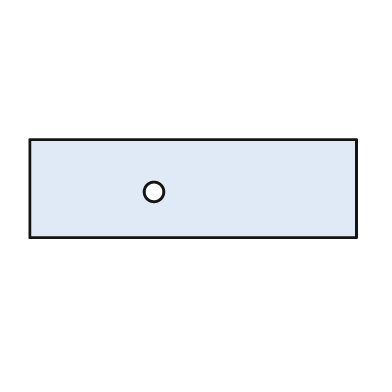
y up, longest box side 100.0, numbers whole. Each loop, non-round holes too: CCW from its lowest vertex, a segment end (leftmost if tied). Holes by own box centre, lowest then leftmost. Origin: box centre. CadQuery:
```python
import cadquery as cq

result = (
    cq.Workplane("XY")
    .moveTo(-50.0, -15.0)
    .lineTo(50.0, -15.0)
    .lineTo(50.0, 15.0)
    .lineTo(-50.0, 15.0)
    .close()
    .moveTo(-12.0, -1.0)
    .circle(3.0)
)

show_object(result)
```